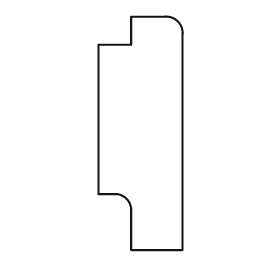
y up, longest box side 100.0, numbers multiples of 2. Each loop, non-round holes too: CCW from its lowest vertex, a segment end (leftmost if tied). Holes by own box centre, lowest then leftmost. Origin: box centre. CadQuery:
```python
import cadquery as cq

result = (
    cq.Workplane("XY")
    .moveTo(-4.0, -50.0)
    .lineTo(18.0, -50.0)
    .lineTo(18.0, 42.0)
    .threePointArc((16.0, 48.0), (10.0, 50.0))
    .lineTo(-4.0, 50.0)
    .lineTo(-4.0, 38.0)
    .lineTo(-18.0, 38.0)
    .lineTo(-18.0, -26.0)
    .lineTo(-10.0, -26.0)
    .threePointArc((-6.0, -28.0), (-4.0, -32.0))
    .close()
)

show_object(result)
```